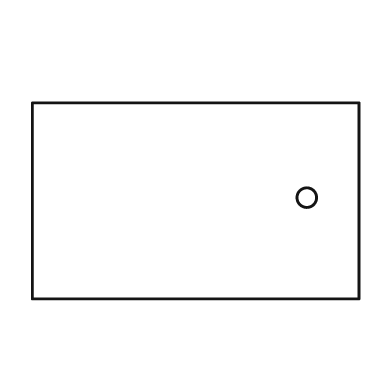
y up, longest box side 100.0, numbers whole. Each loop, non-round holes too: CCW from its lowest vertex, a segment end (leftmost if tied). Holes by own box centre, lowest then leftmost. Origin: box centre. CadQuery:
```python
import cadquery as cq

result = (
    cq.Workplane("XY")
    .moveTo(-50.0, -30.0)
    .lineTo(50.0, -30.0)
    .lineTo(50.0, 30.0)
    .lineTo(-50.0, 30.0)
    .close()
    .moveTo(34.0, 1.0)
    .circle(3.0)
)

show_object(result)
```